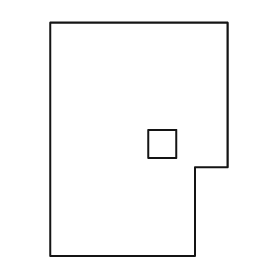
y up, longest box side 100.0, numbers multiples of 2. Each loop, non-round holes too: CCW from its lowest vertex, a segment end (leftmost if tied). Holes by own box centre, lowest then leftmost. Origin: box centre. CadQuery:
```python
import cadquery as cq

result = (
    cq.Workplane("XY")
    .moveTo(-38.0, -50.0)
    .lineTo(24.0, -50.0)
    .lineTo(24.0, -12.0)
    .lineTo(38.0, -12.0)
    .lineTo(38.0, 50.0)
    .lineTo(-38.0, 50.0)
    .close()
    .moveTo(4.0, -8.0)
    .lineTo(16.0, -8.0)
    .lineTo(16.0, 4.0)
    .lineTo(4.0, 4.0)
    .close()
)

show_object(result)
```